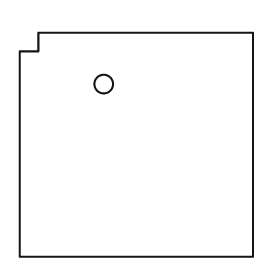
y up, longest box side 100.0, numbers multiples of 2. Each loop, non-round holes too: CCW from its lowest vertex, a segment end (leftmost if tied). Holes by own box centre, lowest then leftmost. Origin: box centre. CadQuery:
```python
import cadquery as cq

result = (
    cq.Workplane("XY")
    .moveTo(-50.0, -48.0)
    .lineTo(50.0, -48.0)
    .lineTo(50.0, 48.0)
    .lineTo(-42.0, 48.0)
    .lineTo(-42.0, 40.0)
    .lineTo(-50.0, 40.0)
    .close()
    .moveTo(-14.0, 26.0)
    .circle(4.0)
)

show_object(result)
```